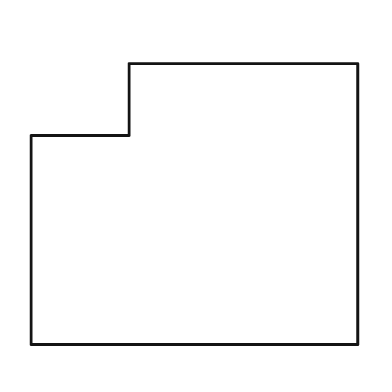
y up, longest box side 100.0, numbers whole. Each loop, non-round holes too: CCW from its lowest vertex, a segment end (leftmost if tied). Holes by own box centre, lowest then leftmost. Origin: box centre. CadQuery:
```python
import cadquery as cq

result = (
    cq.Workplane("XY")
    .moveTo(-50.0, -43.0)
    .lineTo(50.0, -43.0)
    .lineTo(50.0, 43.0)
    .lineTo(-20.0, 43.0)
    .lineTo(-20.0, 21.0)
    .lineTo(-50.0, 21.0)
    .close()
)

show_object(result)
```